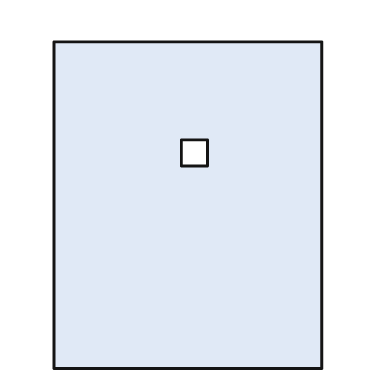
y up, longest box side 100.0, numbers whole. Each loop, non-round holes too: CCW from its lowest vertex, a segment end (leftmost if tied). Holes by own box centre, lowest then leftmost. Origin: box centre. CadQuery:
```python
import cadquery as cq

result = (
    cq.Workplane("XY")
    .moveTo(-41.0, -50.0)
    .lineTo(41.0, -50.0)
    .lineTo(41.0, 50.0)
    .lineTo(-41.0, 50.0)
    .close()
    .moveTo(-2.0, 12.0)
    .lineTo(6.0, 12.0)
    .lineTo(6.0, 20.0)
    .lineTo(-2.0, 20.0)
    .close()
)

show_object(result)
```